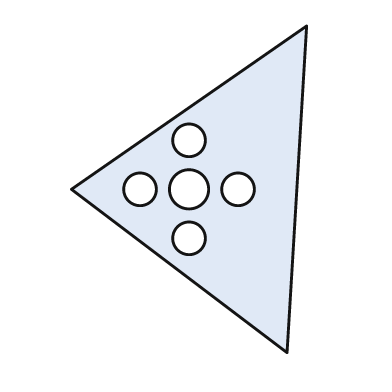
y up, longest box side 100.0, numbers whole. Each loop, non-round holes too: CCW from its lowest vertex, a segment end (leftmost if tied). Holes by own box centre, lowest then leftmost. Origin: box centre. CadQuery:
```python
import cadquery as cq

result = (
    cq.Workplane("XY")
    .moveTo(30.0, -50.0)
    .lineTo(36.0, 50.0)
    .lineTo(-36.0, 0.0)
    .close()
    .moveTo(0.0, -15.0)
    .circle(5.0)
    .moveTo(-15.0, 0.0)
    .circle(5.0)
    .moveTo(0.0, 0.0)
    .circle(6.0)
    .moveTo(15.0, 0.0)
    .circle(5.0)
    .moveTo(0.0, 15.0)
    .circle(5.0)
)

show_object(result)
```